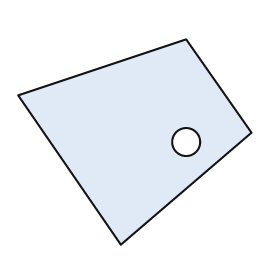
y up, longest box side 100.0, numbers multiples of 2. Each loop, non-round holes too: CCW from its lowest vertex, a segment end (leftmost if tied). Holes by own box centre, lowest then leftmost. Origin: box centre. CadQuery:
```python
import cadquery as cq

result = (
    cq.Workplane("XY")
    .moveTo(-6.0, -44.0)
    .lineTo(50.0, 4.0)
    .lineTo(22.0, 44.0)
    .lineTo(-50.0, 20.0)
    .close()
    .moveTo(22.0, 0.0)
    .circle(6.0)
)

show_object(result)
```